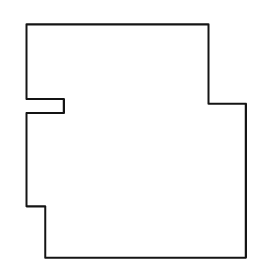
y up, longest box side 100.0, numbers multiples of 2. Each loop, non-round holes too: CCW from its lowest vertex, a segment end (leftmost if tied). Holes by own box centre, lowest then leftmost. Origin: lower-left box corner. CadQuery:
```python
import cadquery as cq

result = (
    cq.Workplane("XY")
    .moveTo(8.0, 0.0)
    .lineTo(94.0, 0.0)
    .lineTo(94.0, 66.0)
    .lineTo(78.0, 66.0)
    .lineTo(78.0, 100.0)
    .lineTo(0.0, 100.0)
    .lineTo(0.0, 68.0)
    .lineTo(16.0, 68.0)
    .lineTo(16.0, 62.0)
    .lineTo(0.0, 62.0)
    .lineTo(0.0, 22.0)
    .lineTo(8.0, 22.0)
    .close()
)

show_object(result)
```